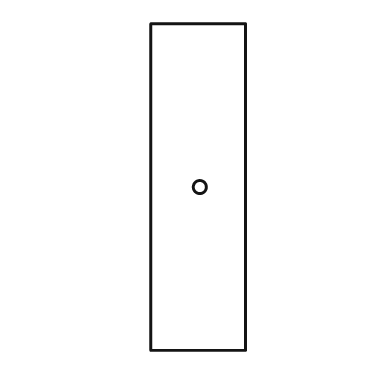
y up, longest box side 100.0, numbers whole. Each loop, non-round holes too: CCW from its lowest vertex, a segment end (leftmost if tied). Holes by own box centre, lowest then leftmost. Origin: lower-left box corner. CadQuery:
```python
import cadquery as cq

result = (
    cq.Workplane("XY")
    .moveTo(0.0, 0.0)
    .lineTo(29.0, 0.0)
    .lineTo(29.0, 100.0)
    .lineTo(0.0, 100.0)
    .close()
    .moveTo(15.0, 50.0)
    .circle(2.0)
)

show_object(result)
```